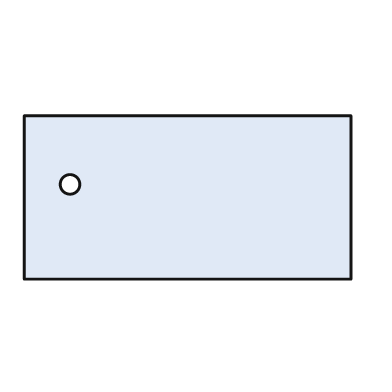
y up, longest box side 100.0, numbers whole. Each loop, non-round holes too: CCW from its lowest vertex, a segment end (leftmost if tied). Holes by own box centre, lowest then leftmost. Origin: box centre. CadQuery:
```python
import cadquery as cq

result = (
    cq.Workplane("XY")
    .moveTo(-50.0, -25.0)
    .lineTo(50.0, -25.0)
    .lineTo(50.0, 25.0)
    .lineTo(-50.0, 25.0)
    .close()
    .moveTo(-36.0, 4.0)
    .circle(3.0)
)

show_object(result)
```